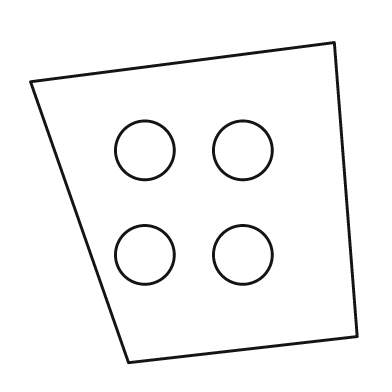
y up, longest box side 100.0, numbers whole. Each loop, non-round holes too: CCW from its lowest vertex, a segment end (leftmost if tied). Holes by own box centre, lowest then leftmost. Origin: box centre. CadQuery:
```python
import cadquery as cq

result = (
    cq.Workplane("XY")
    .moveTo(-20.0, -49.0)
    .lineTo(50.0, -41.0)
    .lineTo(43.0, 49.0)
    .lineTo(-50.0, 37.0)
    .close()
    .moveTo(-15.0, -16.0)
    .circle(9.0)
    .moveTo(15.0, -16.0)
    .circle(9.0)
    .moveTo(-15.0, 16.0)
    .circle(9.0)
    .moveTo(15.0, 16.0)
    .circle(9.0)
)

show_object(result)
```